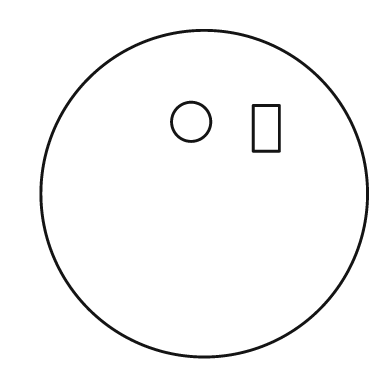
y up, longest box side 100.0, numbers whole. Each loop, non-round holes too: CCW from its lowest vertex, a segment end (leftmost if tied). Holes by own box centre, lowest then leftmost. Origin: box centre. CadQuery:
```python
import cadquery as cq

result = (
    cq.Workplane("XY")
    .moveTo(0.0, 0.0)
    .circle(50.0)
    .moveTo(15.0, 13.0)
    .lineTo(23.0, 13.0)
    .lineTo(23.0, 27.0)
    .lineTo(15.0, 27.0)
    .close()
    .moveTo(-4.0, 22.0)
    .circle(6.0)
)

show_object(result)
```